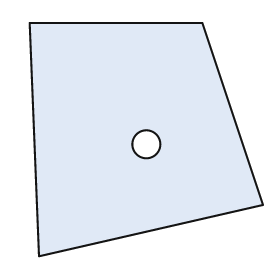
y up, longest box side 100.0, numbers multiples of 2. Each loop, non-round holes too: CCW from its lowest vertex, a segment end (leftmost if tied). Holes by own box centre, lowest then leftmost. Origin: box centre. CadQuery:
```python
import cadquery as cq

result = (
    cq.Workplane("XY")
    .moveTo(-46.0, -50.0)
    .lineTo(50.0, -28.0)
    .lineTo(24.0, 50.0)
    .lineTo(-50.0, 50.0)
    .close()
    .moveTo(0.0, -2.0)
    .circle(6.0)
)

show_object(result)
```